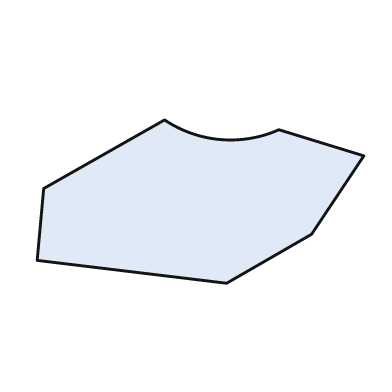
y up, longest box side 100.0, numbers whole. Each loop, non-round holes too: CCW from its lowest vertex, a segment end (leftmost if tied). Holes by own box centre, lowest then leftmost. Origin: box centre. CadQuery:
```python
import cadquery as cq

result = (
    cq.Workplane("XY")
    .moveTo(8.0, -25.0)
    .lineTo(34.0, -10.0)
    .lineTo(50.0, 14.0)
    .lineTo(24.0, 22.0)
    .threePointArc((6.0, 19.0), (-11.0, 25.0))
    .lineTo(-48.0, 4.0)
    .lineTo(-50.0, -18.0)
    .close()
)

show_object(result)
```